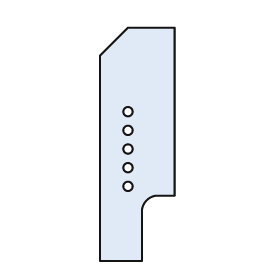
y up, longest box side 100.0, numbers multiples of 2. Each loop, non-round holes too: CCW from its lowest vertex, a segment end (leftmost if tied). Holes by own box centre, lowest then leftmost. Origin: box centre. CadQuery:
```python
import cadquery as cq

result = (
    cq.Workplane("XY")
    .moveTo(-16.0, -50.0)
    .lineTo(2.0, -50.0)
    .lineTo(2.0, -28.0)
    .threePointArc((4.0, -24.0), (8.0, -22.0))
    .lineTo(16.0, -22.0)
    .lineTo(16.0, 50.0)
    .lineTo(-4.0, 50.0)
    .lineTo(-16.0, 38.0)
    .close()
    .moveTo(-4.0, -18.0)
    .circle(2.0)
    .moveTo(-4.0, -10.0)
    .circle(2.0)
    .moveTo(-4.0, -2.0)
    .circle(2.0)
    .moveTo(-4.0, 6.0)
    .circle(2.0)
    .moveTo(-4.0, 14.0)
    .circle(2.0)
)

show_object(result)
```